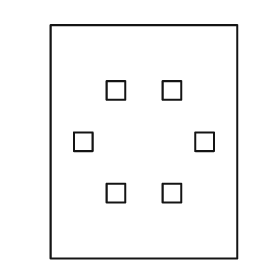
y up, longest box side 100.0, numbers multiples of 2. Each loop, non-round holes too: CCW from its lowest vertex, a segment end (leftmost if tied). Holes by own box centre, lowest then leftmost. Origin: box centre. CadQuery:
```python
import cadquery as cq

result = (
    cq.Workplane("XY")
    .moveTo(-40.0, -50.0)
    .lineTo(40.0, -50.0)
    .lineTo(40.0, 50.0)
    .lineTo(-40.0, 50.0)
    .close()
    .moveTo(-16.0, -26.0)
    .lineTo(-8.0, -26.0)
    .lineTo(-8.0, -18.0)
    .lineTo(-16.0, -18.0)
    .close()
    .moveTo(8.0, -26.0)
    .lineTo(16.0, -26.0)
    .lineTo(16.0, -18.0)
    .lineTo(8.0, -18.0)
    .close()
    .moveTo(-30.0, -4.0)
    .lineTo(-22.0, -4.0)
    .lineTo(-22.0, 4.0)
    .lineTo(-30.0, 4.0)
    .close()
    .moveTo(22.0, -4.0)
    .lineTo(30.0, -4.0)
    .lineTo(30.0, 4.0)
    .lineTo(22.0, 4.0)
    .close()
    .moveTo(-16.0, 18.0)
    .lineTo(-8.0, 18.0)
    .lineTo(-8.0, 26.0)
    .lineTo(-16.0, 26.0)
    .close()
    .moveTo(8.0, 18.0)
    .lineTo(16.0, 18.0)
    .lineTo(16.0, 26.0)
    .lineTo(8.0, 26.0)
    .close()
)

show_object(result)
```